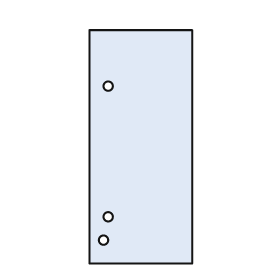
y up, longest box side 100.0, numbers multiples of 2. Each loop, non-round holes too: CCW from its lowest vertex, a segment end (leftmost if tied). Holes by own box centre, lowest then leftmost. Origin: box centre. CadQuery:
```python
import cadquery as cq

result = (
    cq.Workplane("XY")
    .moveTo(-22.0, -50.0)
    .lineTo(22.0, -50.0)
    .lineTo(22.0, 50.0)
    .lineTo(-22.0, 50.0)
    .close()
    .moveTo(-16.0, -40.0)
    .circle(2.0)
    .moveTo(-14.0, -30.0)
    .circle(2.0)
    .moveTo(-14.0, 26.0)
    .circle(2.0)
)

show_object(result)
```